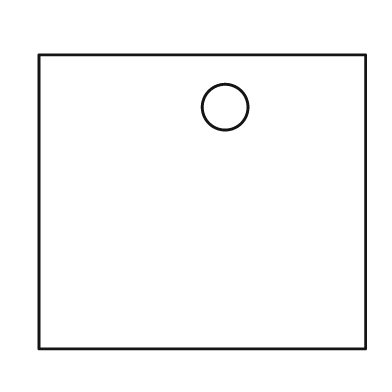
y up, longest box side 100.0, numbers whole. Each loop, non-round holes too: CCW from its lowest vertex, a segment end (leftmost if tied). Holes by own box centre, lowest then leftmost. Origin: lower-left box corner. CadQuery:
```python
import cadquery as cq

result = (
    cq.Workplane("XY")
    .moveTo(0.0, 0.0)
    .lineTo(100.0, 0.0)
    .lineTo(100.0, 90.0)
    .lineTo(0.0, 90.0)
    .close()
    .moveTo(57.0, 74.0)
    .circle(7.0)
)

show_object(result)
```